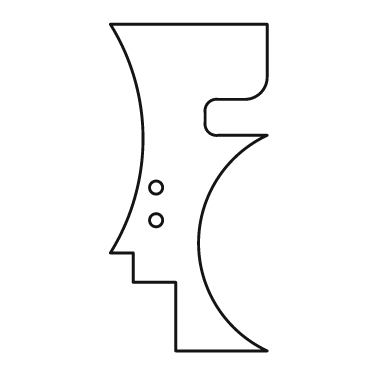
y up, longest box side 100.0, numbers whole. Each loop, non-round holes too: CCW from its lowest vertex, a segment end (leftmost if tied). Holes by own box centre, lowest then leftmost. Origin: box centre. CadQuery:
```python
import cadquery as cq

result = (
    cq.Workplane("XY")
    .moveTo(-4.0, -50.0)
    .lineTo(24.0, -50.0)
    .threePointArc((3.0, -17.0), (24.0, 16.0))
    .lineTo(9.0, 16.0)
    .threePointArc((6.0, 17.0), (5.0, 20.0))
    .lineTo(5.0, 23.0)
    .threePointArc((6.0, 26.0), (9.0, 27.0))
    .lineTo(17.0, 27.0)
    .threePointArc((22.0, 29.0), (24.0, 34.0))
    .lineTo(24.0, 50.0)
    .lineTo(-24.0, 50.0)
    .threePointArc((-14.0, 15.0), (-24.0, -20.0))
    .lineTo(-17.0, -20.0)
    .lineTo(-17.0, -29.0)
    .lineTo(-4.0, -29.0)
    .close()
    .moveTo(-10.0, -10.0)
    .circle(2.0)
    .moveTo(-10.0, 0.0)
    .circle(2.0)
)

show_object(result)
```